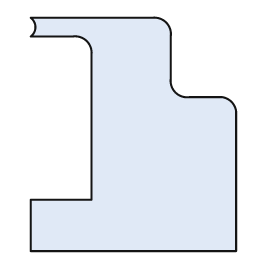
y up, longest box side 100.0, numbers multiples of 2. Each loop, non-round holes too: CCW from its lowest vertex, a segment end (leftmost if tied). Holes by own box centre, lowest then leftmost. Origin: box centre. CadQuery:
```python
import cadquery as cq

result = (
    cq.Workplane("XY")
    .moveTo(-44.0, -50.0)
    .lineTo(44.0, -50.0)
    .lineTo(44.0, 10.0)
    .threePointArc((42.0, 14.0), (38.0, 16.0))
    .lineTo(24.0, 16.0)
    .threePointArc((18.0, 18.0), (16.0, 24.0))
    .lineTo(16.0, 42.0)
    .threePointArc((14.0, 48.0), (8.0, 50.0))
    .lineTo(-44.0, 50.0)
    .threePointArc((-42.0, 46.0), (-44.0, 42.0))
    .lineTo(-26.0, 42.0)
    .threePointArc((-20.0, 40.0), (-18.0, 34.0))
    .lineTo(-18.0, -28.0)
    .lineTo(-44.0, -28.0)
    .close()
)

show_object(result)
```